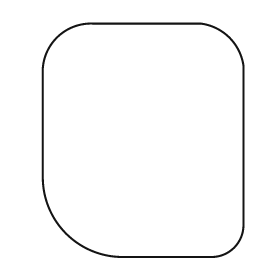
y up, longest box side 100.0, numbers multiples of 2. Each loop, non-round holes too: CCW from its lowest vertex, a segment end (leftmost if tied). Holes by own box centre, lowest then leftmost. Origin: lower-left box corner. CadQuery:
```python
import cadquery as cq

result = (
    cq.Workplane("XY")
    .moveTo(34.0, 0.0)
    .lineTo(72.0, 0.0)
    .threePointArc((82.0, 4.0), (86.0, 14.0))
    .lineTo(86.0, 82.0)
    .threePointArc((80.0, 94.0), (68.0, 100.0))
    .lineTo(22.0, 100.0)
    .threePointArc((6.0, 94.0), (0.0, 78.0))
    .lineTo(0.0, 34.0)
    .threePointArc((10.0, 10.0), (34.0, 0.0))
    .close()
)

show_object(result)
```